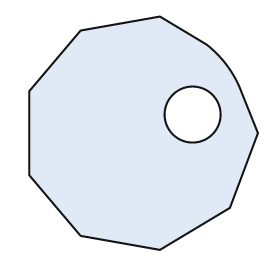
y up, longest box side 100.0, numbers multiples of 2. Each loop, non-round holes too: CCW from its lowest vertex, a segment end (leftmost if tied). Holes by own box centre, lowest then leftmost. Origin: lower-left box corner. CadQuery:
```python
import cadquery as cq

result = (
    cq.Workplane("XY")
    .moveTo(56.0, 0.0)
    .lineTo(86.0, 18.0)
    .lineTo(98.0, 50.0)
    .lineTo(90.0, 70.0)
    .threePointArc((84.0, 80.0), (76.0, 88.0))
    .lineTo(56.0, 100.0)
    .lineTo(22.0, 94.0)
    .lineTo(0.0, 68.0)
    .lineTo(0.0, 32.0)
    .lineTo(22.0, 6.0)
    .close()
    .moveTo(70.0, 58.0)
    .circle(12.0)
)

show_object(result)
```